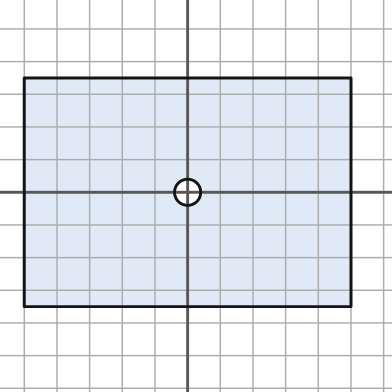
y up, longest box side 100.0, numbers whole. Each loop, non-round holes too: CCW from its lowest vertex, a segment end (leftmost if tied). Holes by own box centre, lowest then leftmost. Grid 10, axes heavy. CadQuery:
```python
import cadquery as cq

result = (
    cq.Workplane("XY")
    .moveTo(-50.0, -35.0)
    .lineTo(50.0, -35.0)
    .lineTo(50.0, 35.0)
    .lineTo(-50.0, 35.0)
    .close()
    .moveTo(0.0, 0.0)
    .circle(4.0)
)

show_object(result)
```